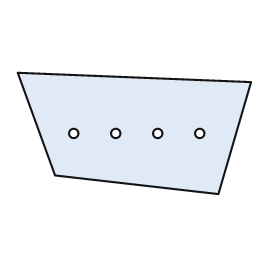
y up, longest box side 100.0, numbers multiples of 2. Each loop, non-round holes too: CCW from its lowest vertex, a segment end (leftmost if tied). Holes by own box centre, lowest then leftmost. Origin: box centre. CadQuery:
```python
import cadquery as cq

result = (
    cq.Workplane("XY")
    .moveTo(36.0, -26.0)
    .lineTo(50.0, 22.0)
    .lineTo(-50.0, 26.0)
    .lineTo(-34.0, -18.0)
    .close()
    .moveTo(-26.0, 0.0)
    .circle(2.0)
    .moveTo(-8.0, 0.0)
    .circle(2.0)
    .moveTo(10.0, 0.0)
    .circle(2.0)
    .moveTo(28.0, 0.0)
    .circle(2.0)
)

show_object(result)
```